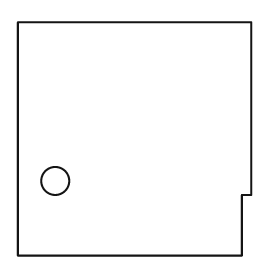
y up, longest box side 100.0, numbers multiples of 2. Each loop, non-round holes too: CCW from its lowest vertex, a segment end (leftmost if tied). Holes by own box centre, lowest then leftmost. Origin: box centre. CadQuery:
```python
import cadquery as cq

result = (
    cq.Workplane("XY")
    .moveTo(-50.0, -50.0)
    .lineTo(46.0, -50.0)
    .lineTo(46.0, -24.0)
    .lineTo(50.0, -24.0)
    .lineTo(50.0, 50.0)
    .lineTo(-50.0, 50.0)
    .close()
    .moveTo(-34.0, -18.0)
    .circle(6.0)
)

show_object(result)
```